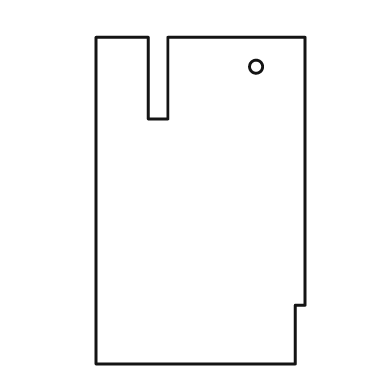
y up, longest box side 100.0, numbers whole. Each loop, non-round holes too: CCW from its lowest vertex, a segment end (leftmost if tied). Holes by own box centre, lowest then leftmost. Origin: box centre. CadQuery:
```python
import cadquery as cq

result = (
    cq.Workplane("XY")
    .moveTo(-32.0, -50.0)
    .lineTo(29.0, -50.0)
    .lineTo(29.0, -32.0)
    .lineTo(32.0, -32.0)
    .lineTo(32.0, 50.0)
    .lineTo(-10.0, 50.0)
    .lineTo(-10.0, 25.0)
    .lineTo(-16.0, 25.0)
    .lineTo(-16.0, 50.0)
    .lineTo(-32.0, 50.0)
    .close()
    .moveTo(17.0, 41.0)
    .circle(2.0)
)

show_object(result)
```